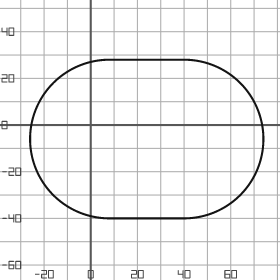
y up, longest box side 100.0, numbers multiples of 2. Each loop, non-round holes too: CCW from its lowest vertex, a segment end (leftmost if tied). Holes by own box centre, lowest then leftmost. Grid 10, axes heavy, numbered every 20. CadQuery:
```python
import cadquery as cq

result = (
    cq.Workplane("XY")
    .moveTo(8.0, -40.0)
    .lineTo(40.0, -40.0)
    .threePointArc((74.0, -6.0), (40.0, 28.0))
    .lineTo(8.0, 28.0)
    .threePointArc((-26.0, -6.0), (8.0, -40.0))
    .close()
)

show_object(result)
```